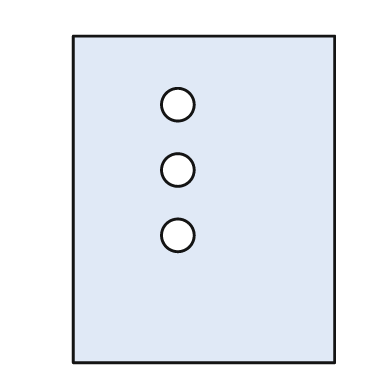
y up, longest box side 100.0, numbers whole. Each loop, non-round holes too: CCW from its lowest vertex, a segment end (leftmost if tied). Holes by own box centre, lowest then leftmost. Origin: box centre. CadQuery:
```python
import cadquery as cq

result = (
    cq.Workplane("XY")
    .moveTo(-40.0, -50.0)
    .lineTo(40.0, -50.0)
    .lineTo(40.0, 50.0)
    .lineTo(-40.0, 50.0)
    .close()
    .moveTo(-8.0, -11.0)
    .circle(5.0)
    .moveTo(-8.0, 9.0)
    .circle(5.0)
    .moveTo(-8.0, 29.0)
    .circle(5.0)
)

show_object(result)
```